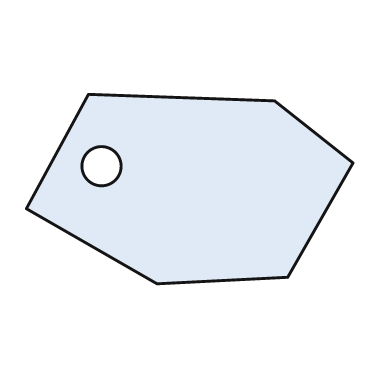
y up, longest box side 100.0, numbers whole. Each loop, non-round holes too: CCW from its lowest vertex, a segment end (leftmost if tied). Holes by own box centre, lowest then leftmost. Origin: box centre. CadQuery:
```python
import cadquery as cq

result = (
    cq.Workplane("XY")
    .moveTo(-10.0, -29.0)
    .lineTo(30.0, -27.0)
    .lineTo(50.0, 8.0)
    .lineTo(26.0, 27.0)
    .lineTo(-31.0, 29.0)
    .lineTo(-50.0, -6.0)
    .close()
    .moveTo(-27.0, 7.0)
    .circle(6.0)
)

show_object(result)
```